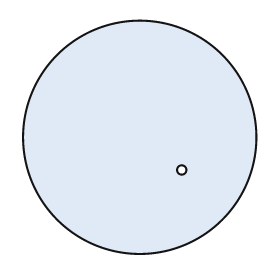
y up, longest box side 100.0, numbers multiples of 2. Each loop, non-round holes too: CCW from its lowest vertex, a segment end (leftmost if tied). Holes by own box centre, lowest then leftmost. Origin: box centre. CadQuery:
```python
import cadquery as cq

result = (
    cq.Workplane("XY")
    .moveTo(0.0, 0.0)
    .circle(50.0)
    .moveTo(18.0, -14.0)
    .circle(2.0)
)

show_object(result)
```